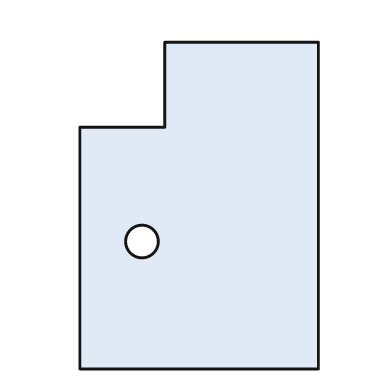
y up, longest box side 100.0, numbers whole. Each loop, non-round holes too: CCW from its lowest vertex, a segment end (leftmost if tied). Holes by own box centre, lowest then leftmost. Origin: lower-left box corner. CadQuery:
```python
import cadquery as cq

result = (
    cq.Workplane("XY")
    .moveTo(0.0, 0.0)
    .lineTo(73.0, 0.0)
    .lineTo(73.0, 100.0)
    .lineTo(26.0, 100.0)
    .lineTo(26.0, 74.0)
    .lineTo(0.0, 74.0)
    .close()
    .moveTo(19.0, 39.0)
    .circle(5.0)
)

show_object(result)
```